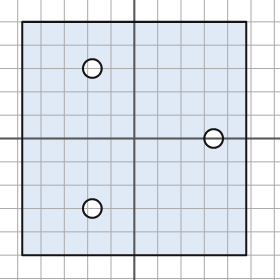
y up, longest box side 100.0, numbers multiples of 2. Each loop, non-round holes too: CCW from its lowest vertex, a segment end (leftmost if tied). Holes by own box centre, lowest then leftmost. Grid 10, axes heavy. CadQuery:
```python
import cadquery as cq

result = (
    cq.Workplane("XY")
    .moveTo(-48.0, -50.0)
    .lineTo(48.0, -50.0)
    .lineTo(48.0, 50.0)
    .lineTo(-48.0, 50.0)
    .close()
    .moveTo(-18.0, -30.0)
    .circle(4.0)
    .moveTo(34.0, 0.0)
    .circle(4.0)
    .moveTo(-18.0, 30.0)
    .circle(4.0)
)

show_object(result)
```